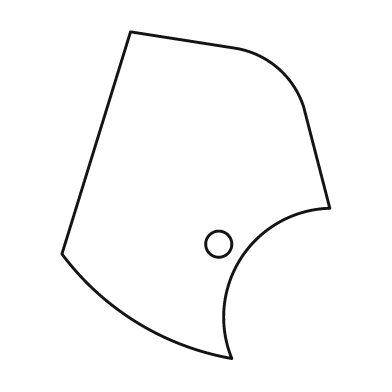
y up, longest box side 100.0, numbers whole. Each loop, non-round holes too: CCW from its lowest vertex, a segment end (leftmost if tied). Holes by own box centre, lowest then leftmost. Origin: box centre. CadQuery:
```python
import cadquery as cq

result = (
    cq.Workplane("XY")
    .moveTo(11.0, -50.0)
    .threePointArc((14.0, -19.0), (41.0, -4.0))
    .lineTo(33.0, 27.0)
    .threePointArc((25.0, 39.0), (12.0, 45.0))
    .lineTo(-20.0, 50.0)
    .lineTo(-41.0, -18.0)
    .threePointArc((-18.0, -39.0), (11.0, -50.0))
    .close()
    .moveTo(7.0, -15.0)
    .circle(4.0)
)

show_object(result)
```